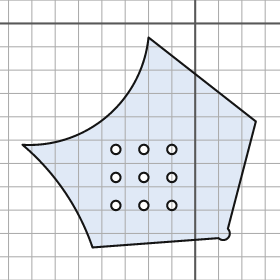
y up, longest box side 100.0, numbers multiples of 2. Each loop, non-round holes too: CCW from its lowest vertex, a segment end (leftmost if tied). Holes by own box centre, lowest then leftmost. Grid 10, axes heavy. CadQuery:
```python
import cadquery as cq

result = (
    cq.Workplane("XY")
    .moveTo(-44.0, -96.0)
    .lineTo(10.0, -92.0)
    .threePointArc((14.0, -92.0), (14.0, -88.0))
    .lineTo(26.0, -42.0)
    .lineTo(-20.0, -6.0)
    .threePointArc((-38.0, -40.0), (-74.0, -52.0))
    .threePointArc((-56.0, -72.0), (-44.0, -96.0))
    .close()
    .moveTo(-34.0, -78.0)
    .circle(2.0)
    .moveTo(-22.0, -78.0)
    .circle(2.0)
    .moveTo(-10.0, -78.0)
    .circle(2.0)
    .moveTo(-34.0, -66.0)
    .circle(2.0)
    .moveTo(-22.0, -66.0)
    .circle(2.0)
    .moveTo(-10.0, -66.0)
    .circle(2.0)
    .moveTo(-34.0, -54.0)
    .circle(2.0)
    .moveTo(-22.0, -54.0)
    .circle(2.0)
    .moveTo(-10.0, -54.0)
    .circle(2.0)
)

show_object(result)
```